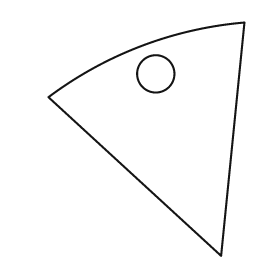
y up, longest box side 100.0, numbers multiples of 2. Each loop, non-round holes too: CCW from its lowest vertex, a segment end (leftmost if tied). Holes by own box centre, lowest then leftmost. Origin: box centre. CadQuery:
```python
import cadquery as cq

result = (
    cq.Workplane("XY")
    .moveTo(32.0, -50.0)
    .lineTo(42.0, 50.0)
    .threePointArc((-2.0, 40.0), (-42.0, 18.0))
    .close()
    .moveTo(4.0, 28.0)
    .circle(8.0)
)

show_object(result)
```